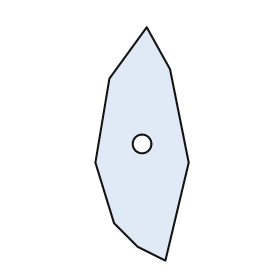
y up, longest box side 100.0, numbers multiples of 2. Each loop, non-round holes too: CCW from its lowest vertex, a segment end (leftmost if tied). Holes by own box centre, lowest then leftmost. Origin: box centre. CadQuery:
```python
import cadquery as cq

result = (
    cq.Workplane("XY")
    .moveTo(10.0, -50.0)
    .lineTo(20.0, -8.0)
    .lineTo(12.0, 32.0)
    .lineTo(2.0, 50.0)
    .lineTo(-14.0, 28.0)
    .lineTo(-20.0, -8.0)
    .lineTo(-12.0, -34.0)
    .lineTo(-2.0, -44.0)
    .close()
    .moveTo(0.0, 0.0)
    .circle(4.0)
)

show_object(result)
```